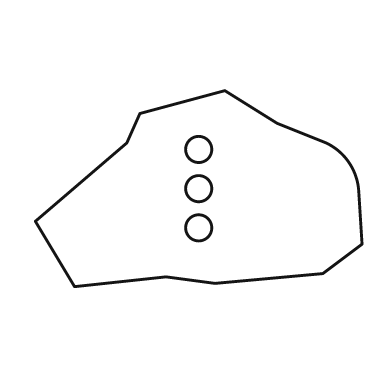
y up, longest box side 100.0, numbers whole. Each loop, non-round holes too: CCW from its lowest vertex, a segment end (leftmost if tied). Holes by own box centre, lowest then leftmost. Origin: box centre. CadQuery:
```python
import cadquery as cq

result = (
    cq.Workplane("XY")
    .moveTo(-38.0, -30.0)
    .lineTo(-10.0, -27.0)
    .lineTo(5.0, -29.0)
    .lineTo(38.0, -26.0)
    .lineTo(50.0, -17.0)
    .lineTo(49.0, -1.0)
    .threePointArc((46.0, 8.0), (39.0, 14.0))
    .lineTo(24.0, 20.0)
    .lineTo(8.0, 30.0)
    .lineTo(-18.0, 23.0)
    .lineTo(-22.0, 14.0)
    .lineTo(-50.0, -10.0)
    .close()
    .moveTo(0.0, -12.0)
    .circle(4.0)
    .moveTo(0.0, 0.0)
    .circle(4.0)
    .moveTo(0.0, 12.0)
    .circle(4.0)
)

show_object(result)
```